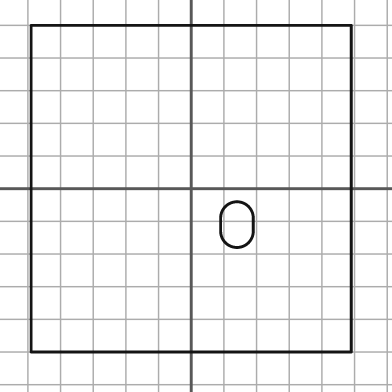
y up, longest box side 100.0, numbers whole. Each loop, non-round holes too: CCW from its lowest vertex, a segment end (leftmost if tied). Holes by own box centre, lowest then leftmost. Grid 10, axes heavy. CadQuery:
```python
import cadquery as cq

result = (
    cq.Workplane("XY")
    .moveTo(-49.0, -50.0)
    .lineTo(49.0, -50.0)
    .lineTo(49.0, 50.0)
    .lineTo(-49.0, 50.0)
    .close()
    .moveTo(9.0, -13.0)
    .threePointArc((14.0, -18.0), (19.0, -13.0))
    .lineTo(19.0, -9.0)
    .threePointArc((14.0, -4.0), (9.0, -9.0))
    .close()
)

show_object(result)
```